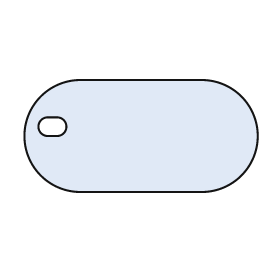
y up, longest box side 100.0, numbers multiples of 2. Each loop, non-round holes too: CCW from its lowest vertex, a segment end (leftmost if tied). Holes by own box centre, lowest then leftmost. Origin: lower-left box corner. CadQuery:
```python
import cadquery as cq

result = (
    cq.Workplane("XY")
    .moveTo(24.0, 0.0)
    .lineTo(76.0, 0.0)
    .threePointArc((100.0, 24.0), (76.0, 48.0))
    .lineTo(24.0, 48.0)
    .threePointArc((0.0, 24.0), (24.0, 0.0))
    .close()
    .moveTo(10.0, 24.0)
    .lineTo(14.0, 24.0)
    .threePointArc((18.0, 28.0), (14.0, 32.0))
    .lineTo(10.0, 32.0)
    .threePointArc((6.0, 28.0), (10.0, 24.0))
    .close()
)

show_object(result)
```